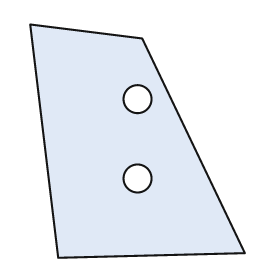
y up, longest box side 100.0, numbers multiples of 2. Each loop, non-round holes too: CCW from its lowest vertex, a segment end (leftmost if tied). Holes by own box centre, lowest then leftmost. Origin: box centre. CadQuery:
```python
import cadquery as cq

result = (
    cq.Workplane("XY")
    .moveTo(-34.0, -50.0)
    .lineTo(46.0, -48.0)
    .lineTo(2.0, 44.0)
    .lineTo(-46.0, 50.0)
    .close()
    .moveTo(0.0, -16.0)
    .circle(6.0)
    .moveTo(0.0, 18.0)
    .circle(6.0)
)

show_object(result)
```